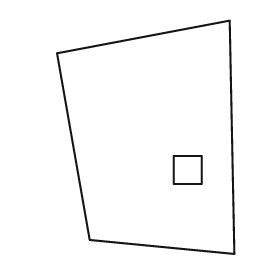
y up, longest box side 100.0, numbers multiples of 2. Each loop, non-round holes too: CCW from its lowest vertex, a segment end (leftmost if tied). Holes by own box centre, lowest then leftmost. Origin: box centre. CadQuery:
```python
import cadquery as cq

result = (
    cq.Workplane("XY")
    .moveTo(38.0, -50.0)
    .lineTo(36.0, 50.0)
    .lineTo(-38.0, 36.0)
    .lineTo(-24.0, -44.0)
    .close()
    .moveTo(12.0, -20.0)
    .lineTo(24.0, -20.0)
    .lineTo(24.0, -8.0)
    .lineTo(12.0, -8.0)
    .close()
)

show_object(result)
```